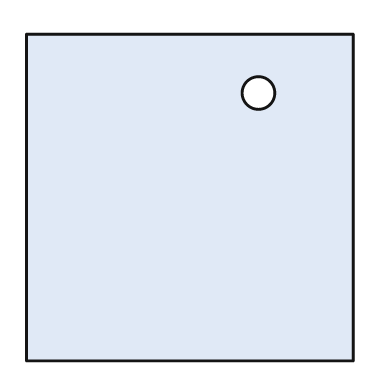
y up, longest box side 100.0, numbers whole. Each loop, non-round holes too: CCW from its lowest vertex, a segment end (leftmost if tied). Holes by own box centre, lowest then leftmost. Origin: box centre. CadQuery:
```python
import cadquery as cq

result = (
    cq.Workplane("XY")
    .moveTo(-50.0, -50.0)
    .lineTo(50.0, -50.0)
    .lineTo(50.0, 50.0)
    .lineTo(-50.0, 50.0)
    .close()
    .moveTo(21.0, 32.0)
    .circle(5.0)
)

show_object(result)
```